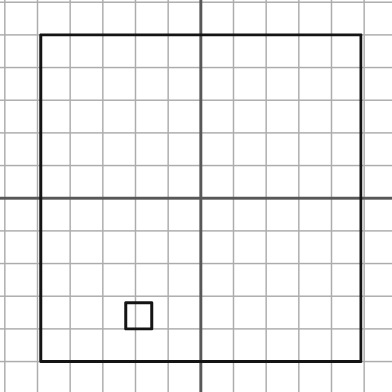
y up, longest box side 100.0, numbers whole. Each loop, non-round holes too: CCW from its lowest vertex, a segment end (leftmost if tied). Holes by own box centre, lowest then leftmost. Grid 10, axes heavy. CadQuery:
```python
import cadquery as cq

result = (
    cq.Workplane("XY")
    .moveTo(-49.0, -50.0)
    .lineTo(49.0, -50.0)
    .lineTo(49.0, 50.0)
    .lineTo(-49.0, 50.0)
    .close()
    .moveTo(-23.0, -40.0)
    .lineTo(-15.0, -40.0)
    .lineTo(-15.0, -32.0)
    .lineTo(-23.0, -32.0)
    .close()
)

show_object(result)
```